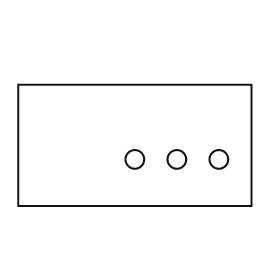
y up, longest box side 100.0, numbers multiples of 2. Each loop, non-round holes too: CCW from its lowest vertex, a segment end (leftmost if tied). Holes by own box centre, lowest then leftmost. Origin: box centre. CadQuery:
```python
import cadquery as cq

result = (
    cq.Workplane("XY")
    .moveTo(-50.0, -26.0)
    .lineTo(50.0, -26.0)
    .lineTo(50.0, 26.0)
    .lineTo(-50.0, 26.0)
    .close()
    .moveTo(0.0, -6.0)
    .circle(4.0)
    .moveTo(18.0, -6.0)
    .circle(4.0)
    .moveTo(36.0, -6.0)
    .circle(4.0)
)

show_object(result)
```